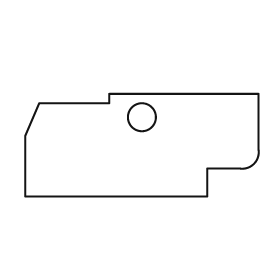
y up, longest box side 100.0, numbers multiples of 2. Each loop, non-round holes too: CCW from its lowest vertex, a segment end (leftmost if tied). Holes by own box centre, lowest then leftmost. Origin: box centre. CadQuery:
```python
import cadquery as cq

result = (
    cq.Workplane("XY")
    .moveTo(-50.0, -22.0)
    .lineTo(28.0, -22.0)
    .lineTo(28.0, -10.0)
    .lineTo(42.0, -10.0)
    .threePointArc((48.0, -8.0), (50.0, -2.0))
    .lineTo(50.0, 22.0)
    .lineTo(-14.0, 22.0)
    .lineTo(-14.0, 18.0)
    .lineTo(-44.0, 18.0)
    .lineTo(-50.0, 4.0)
    .close()
    .moveTo(0.0, 12.0)
    .circle(6.0)
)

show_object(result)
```